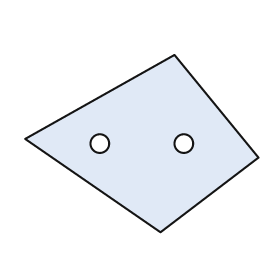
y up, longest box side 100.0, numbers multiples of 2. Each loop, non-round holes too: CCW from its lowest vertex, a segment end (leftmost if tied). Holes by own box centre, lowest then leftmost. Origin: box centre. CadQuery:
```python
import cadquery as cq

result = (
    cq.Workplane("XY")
    .moveTo(8.0, -38.0)
    .lineTo(50.0, -6.0)
    .lineTo(14.0, 38.0)
    .lineTo(-50.0, 2.0)
    .close()
    .moveTo(-18.0, 0.0)
    .circle(4.0)
    .moveTo(18.0, 0.0)
    .circle(4.0)
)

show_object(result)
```